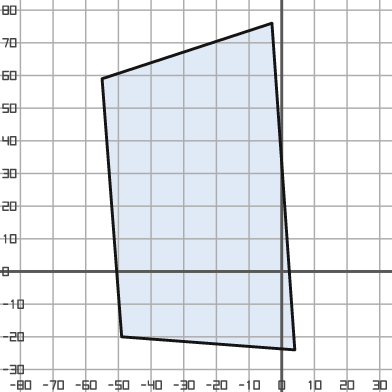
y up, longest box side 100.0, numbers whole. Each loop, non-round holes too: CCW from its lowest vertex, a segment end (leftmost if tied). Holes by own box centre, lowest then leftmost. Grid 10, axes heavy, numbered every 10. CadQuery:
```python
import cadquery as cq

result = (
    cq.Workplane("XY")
    .moveTo(4.0, -24.0)
    .lineTo(-3.0, 76.0)
    .lineTo(-55.0, 59.0)
    .lineTo(-49.0, -20.0)
    .close()
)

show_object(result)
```